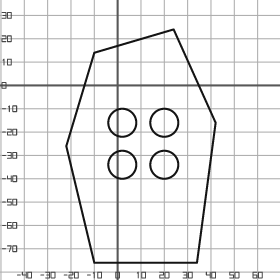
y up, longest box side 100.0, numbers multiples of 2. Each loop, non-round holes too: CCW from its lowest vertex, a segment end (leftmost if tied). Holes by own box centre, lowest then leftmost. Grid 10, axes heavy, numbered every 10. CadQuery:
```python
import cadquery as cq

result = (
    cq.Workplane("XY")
    .moveTo(-10.0, -76.0)
    .lineTo(34.0, -76.0)
    .lineTo(42.0, -16.0)
    .lineTo(24.0, 24.0)
    .lineTo(-10.0, 14.0)
    .lineTo(-22.0, -26.0)
    .close()
    .moveTo(2.0, -34.0)
    .circle(6.0)
    .moveTo(20.0, -34.0)
    .circle(6.0)
    .moveTo(2.0, -16.0)
    .circle(6.0)
    .moveTo(20.0, -16.0)
    .circle(6.0)
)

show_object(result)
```